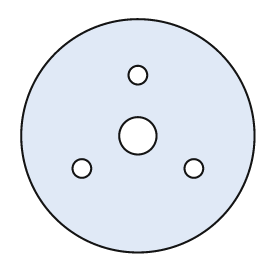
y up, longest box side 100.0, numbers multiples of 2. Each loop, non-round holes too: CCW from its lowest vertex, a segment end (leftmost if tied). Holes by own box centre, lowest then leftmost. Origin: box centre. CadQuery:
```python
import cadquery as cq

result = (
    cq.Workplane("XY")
    .moveTo(0.0, 0.0)
    .circle(50.0)
    .moveTo(-24.0, -14.0)
    .circle(4.0)
    .moveTo(24.0, -14.0)
    .circle(4.0)
    .moveTo(0.0, 0.0)
    .circle(8.0)
    .moveTo(0.0, 26.0)
    .circle(4.0)
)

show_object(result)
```